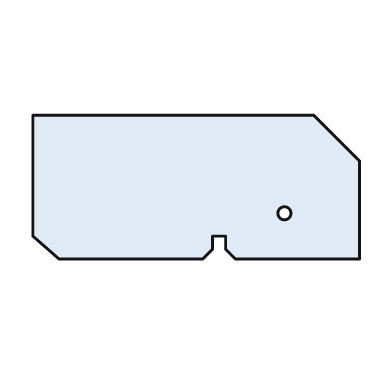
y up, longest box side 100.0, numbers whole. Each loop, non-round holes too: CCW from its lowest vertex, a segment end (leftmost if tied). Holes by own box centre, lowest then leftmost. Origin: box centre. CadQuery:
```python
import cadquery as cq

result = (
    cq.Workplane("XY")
    .moveTo(-42.0, -22.0)
    .lineTo(2.0, -22.0)
    .lineTo(5.0, -19.0)
    .lineTo(5.0, -15.0)
    .lineTo(9.0, -15.0)
    .lineTo(9.0, -19.0)
    .lineTo(12.0, -22.0)
    .lineTo(50.0, -22.0)
    .lineTo(50.0, 8.0)
    .lineTo(36.0, 22.0)
    .lineTo(-50.0, 22.0)
    .lineTo(-50.0, -15.0)
    .close()
    .moveTo(27.0, -8.0)
    .circle(2.0)
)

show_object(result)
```